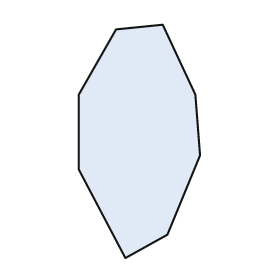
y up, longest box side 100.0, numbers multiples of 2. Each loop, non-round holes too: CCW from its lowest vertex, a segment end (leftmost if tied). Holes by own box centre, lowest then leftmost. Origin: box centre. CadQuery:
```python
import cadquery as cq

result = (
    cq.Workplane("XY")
    .moveTo(-6.0, -50.0)
    .lineTo(12.0, -40.0)
    .lineTo(26.0, -6.0)
    .lineTo(24.0, 20.0)
    .lineTo(10.0, 50.0)
    .lineTo(-10.0, 48.0)
    .lineTo(-26.0, 20.0)
    .lineTo(-26.0, -12.0)
    .close()
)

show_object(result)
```